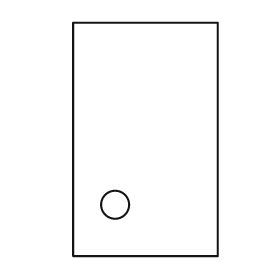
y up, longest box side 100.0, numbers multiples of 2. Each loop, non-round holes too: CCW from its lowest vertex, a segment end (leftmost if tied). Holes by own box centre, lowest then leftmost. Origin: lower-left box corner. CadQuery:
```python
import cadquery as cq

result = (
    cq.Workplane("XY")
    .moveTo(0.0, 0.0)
    .lineTo(62.0, 0.0)
    .lineTo(62.0, 100.0)
    .lineTo(0.0, 100.0)
    .close()
    .moveTo(18.0, 22.0)
    .circle(6.0)
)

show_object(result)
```